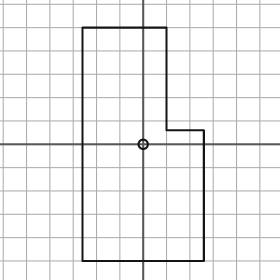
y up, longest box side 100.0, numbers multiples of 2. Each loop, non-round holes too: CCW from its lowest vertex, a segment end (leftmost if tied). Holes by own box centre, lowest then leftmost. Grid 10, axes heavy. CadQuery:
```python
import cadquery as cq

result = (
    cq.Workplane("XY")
    .moveTo(-26.0, -50.0)
    .lineTo(26.0, -50.0)
    .lineTo(26.0, 6.0)
    .lineTo(10.0, 6.0)
    .lineTo(10.0, 50.0)
    .lineTo(-26.0, 50.0)
    .close()
    .moveTo(0.0, 0.0)
    .circle(2.0)
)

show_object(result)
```